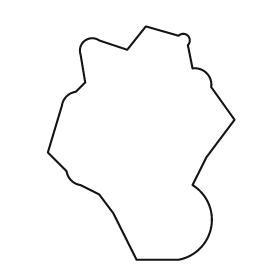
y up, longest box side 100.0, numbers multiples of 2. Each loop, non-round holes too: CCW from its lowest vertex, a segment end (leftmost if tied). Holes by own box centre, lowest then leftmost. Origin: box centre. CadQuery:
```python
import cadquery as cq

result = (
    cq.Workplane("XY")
    .moveTo(-2.0, -50.0)
    .lineTo(16.0, -50.0)
    .threePointArc((30.0, -36.0), (22.0, -18.0))
    .lineTo(28.0, -6.0)
    .lineTo(40.0, 10.0)
    .lineTo(30.0, 24.0)
    .threePointArc((28.0, 30.0), (22.0, 32.0))
    .lineTo(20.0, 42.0)
    .threePointArc((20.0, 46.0), (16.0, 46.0))
    .lineTo(2.0, 50.0)
    .lineTo(-6.0, 40.0)
    .lineTo(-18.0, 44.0)
    .threePointArc((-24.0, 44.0), (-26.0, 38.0))
    .lineTo(-24.0, 26.0)
    .lineTo(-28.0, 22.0)
    .threePointArc((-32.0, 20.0), (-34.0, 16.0))
    .lineTo(-40.0, -4.0)
    .lineTo(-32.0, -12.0)
    .threePointArc((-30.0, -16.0), (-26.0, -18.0))
    .lineTo(-18.0, -22.0)
    .lineTo(-12.0, -30.0)
    .close()
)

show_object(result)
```